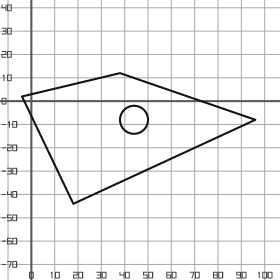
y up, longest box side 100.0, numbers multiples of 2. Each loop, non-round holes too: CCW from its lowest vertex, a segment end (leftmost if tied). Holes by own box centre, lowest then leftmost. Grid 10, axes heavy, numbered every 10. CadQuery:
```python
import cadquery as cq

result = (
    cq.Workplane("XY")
    .moveTo(18.0, -44.0)
    .lineTo(96.0, -8.0)
    .lineTo(38.0, 12.0)
    .lineTo(-4.0, 2.0)
    .close()
    .moveTo(44.0, -8.0)
    .circle(6.0)
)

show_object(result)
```